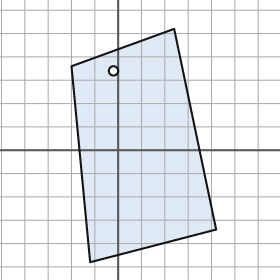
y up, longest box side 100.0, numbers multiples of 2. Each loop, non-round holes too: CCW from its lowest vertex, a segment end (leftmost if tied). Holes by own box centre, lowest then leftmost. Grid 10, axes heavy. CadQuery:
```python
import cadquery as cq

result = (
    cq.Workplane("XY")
    .moveTo(-12.0, -48.0)
    .lineTo(42.0, -34.0)
    .lineTo(24.0, 52.0)
    .lineTo(-20.0, 36.0)
    .close()
    .moveTo(-2.0, 34.0)
    .circle(2.0)
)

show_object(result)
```